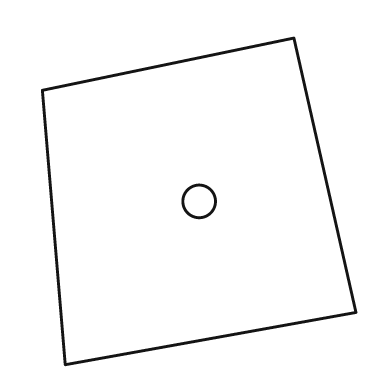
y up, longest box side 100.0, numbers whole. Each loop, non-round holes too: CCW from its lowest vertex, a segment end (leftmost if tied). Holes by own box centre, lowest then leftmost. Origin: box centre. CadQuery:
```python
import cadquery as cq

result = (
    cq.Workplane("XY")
    .moveTo(-41.0, -50.0)
    .lineTo(48.0, -34.0)
    .lineTo(29.0, 50.0)
    .lineTo(-48.0, 34.0)
    .close()
    .moveTo(0.0, 0.0)
    .circle(5.0)
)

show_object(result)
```